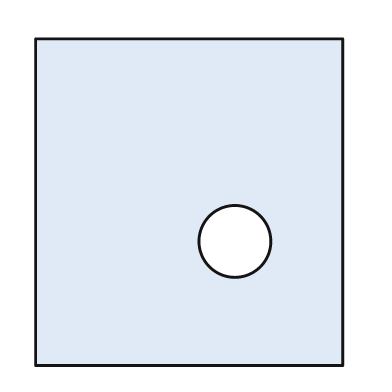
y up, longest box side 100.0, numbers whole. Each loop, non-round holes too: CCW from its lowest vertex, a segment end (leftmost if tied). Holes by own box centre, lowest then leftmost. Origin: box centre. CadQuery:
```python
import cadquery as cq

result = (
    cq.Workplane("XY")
    .moveTo(-47.0, -50.0)
    .lineTo(47.0, -50.0)
    .lineTo(47.0, 50.0)
    .lineTo(-47.0, 50.0)
    .close()
    .moveTo(14.0, -12.0)
    .circle(11.0)
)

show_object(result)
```